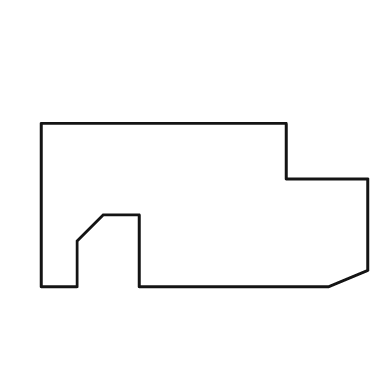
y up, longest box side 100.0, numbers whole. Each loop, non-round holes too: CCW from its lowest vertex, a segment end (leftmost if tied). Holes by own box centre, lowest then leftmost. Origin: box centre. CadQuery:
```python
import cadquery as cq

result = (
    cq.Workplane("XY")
    .moveTo(-50.0, -25.0)
    .lineTo(-39.0, -25.0)
    .lineTo(-39.0, -11.0)
    .lineTo(-31.0, -3.0)
    .lineTo(-20.0, -3.0)
    .lineTo(-20.0, -25.0)
    .lineTo(38.0, -25.0)
    .lineTo(50.0, -20.0)
    .lineTo(50.0, 8.0)
    .lineTo(25.0, 8.0)
    .lineTo(25.0, 25.0)
    .lineTo(-50.0, 25.0)
    .close()
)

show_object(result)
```